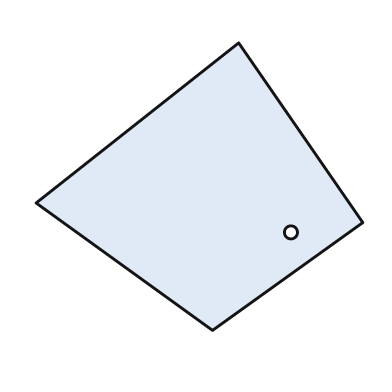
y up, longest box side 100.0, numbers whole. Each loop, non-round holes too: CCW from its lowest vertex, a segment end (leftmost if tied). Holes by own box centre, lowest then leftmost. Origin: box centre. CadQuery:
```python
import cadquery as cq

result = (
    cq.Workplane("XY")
    .moveTo(4.0, -44.0)
    .lineTo(50.0, -11.0)
    .lineTo(12.0, 44.0)
    .lineTo(-50.0, -5.0)
    .close()
    .moveTo(28.0, -14.0)
    .circle(2.0)
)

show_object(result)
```